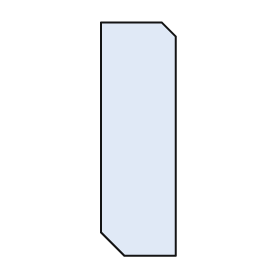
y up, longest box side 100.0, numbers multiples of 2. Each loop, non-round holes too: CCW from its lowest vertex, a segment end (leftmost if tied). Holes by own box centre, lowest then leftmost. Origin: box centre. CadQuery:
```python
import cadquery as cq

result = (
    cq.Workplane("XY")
    .moveTo(-6.0, -50.0)
    .lineTo(16.0, -50.0)
    .lineTo(16.0, 44.0)
    .lineTo(10.0, 50.0)
    .lineTo(-16.0, 50.0)
    .lineTo(-16.0, -40.0)
    .close()
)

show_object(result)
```